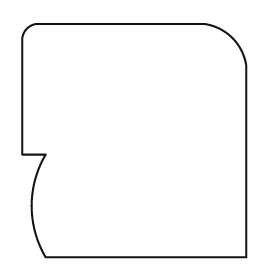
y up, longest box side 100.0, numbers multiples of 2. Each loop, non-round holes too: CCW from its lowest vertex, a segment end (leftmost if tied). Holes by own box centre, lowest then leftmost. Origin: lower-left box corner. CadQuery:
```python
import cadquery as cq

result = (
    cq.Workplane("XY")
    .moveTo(10.0, 0.0)
    .lineTo(96.0, 0.0)
    .lineTo(96.0, 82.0)
    .threePointArc((90.0, 94.0), (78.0, 100.0))
    .lineTo(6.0, 100.0)
    .threePointArc((2.0, 98.0), (0.0, 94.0))
    .lineTo(0.0, 44.0)
    .lineTo(10.0, 44.0)
    .threePointArc((4.0, 22.0), (10.0, 0.0))
    .close()
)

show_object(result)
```